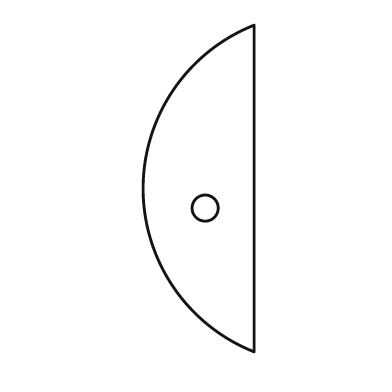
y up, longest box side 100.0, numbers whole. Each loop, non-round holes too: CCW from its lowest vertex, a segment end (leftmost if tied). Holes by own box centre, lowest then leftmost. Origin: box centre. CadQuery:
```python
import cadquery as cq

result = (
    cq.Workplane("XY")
    .moveTo(17.0, -50.0)
    .lineTo(17.0, 50.0)
    .threePointArc((-17.0, 0.0), (17.0, -50.0))
    .close()
    .moveTo(2.0, -6.0)
    .circle(4.0)
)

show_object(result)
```